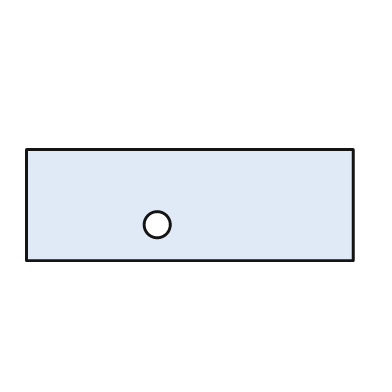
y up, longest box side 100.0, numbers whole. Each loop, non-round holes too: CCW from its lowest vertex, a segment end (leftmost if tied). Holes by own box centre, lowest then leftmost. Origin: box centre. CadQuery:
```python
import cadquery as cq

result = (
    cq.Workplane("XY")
    .moveTo(-50.0, -17.0)
    .lineTo(50.0, -17.0)
    .lineTo(50.0, 17.0)
    .lineTo(-50.0, 17.0)
    .close()
    .moveTo(-10.0, -6.0)
    .circle(4.0)
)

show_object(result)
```